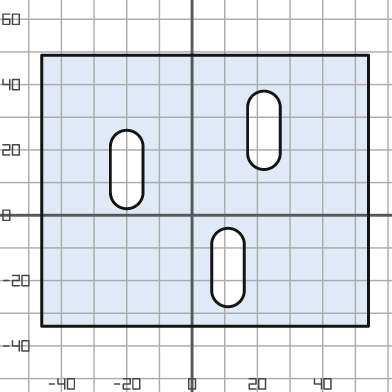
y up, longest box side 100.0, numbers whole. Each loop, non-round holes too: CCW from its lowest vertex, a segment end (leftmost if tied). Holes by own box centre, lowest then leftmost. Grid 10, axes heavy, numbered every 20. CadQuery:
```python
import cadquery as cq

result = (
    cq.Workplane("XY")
    .moveTo(-46.0, -34.0)
    .lineTo(54.0, -34.0)
    .lineTo(54.0, 49.0)
    .lineTo(-46.0, 49.0)
    .close()
    .moveTo(6.0, -23.0)
    .threePointArc((11.0, -28.0), (16.0, -23.0))
    .lineTo(16.0, -9.0)
    .threePointArc((11.0, -4.0), (6.0, -9.0))
    .close()
    .moveTo(-25.0, 7.0)
    .threePointArc((-20.0, 2.0), (-15.0, 7.0))
    .lineTo(-15.0, 21.0)
    .threePointArc((-20.0, 26.0), (-25.0, 21.0))
    .close()
    .moveTo(17.0, 19.0)
    .threePointArc((22.0, 14.0), (27.0, 19.0))
    .lineTo(27.0, 33.0)
    .threePointArc((22.0, 38.0), (17.0, 33.0))
    .close()
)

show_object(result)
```